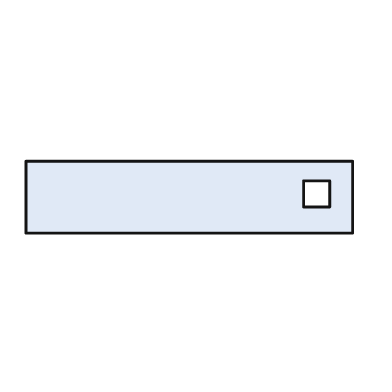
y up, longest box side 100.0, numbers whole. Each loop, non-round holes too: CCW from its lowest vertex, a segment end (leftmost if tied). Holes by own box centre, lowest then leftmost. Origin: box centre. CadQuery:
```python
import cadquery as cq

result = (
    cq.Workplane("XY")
    .moveTo(-50.0, -11.0)
    .lineTo(50.0, -11.0)
    .lineTo(50.0, 11.0)
    .lineTo(-50.0, 11.0)
    .close()
    .moveTo(35.0, -3.0)
    .lineTo(43.0, -3.0)
    .lineTo(43.0, 5.0)
    .lineTo(35.0, 5.0)
    .close()
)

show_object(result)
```